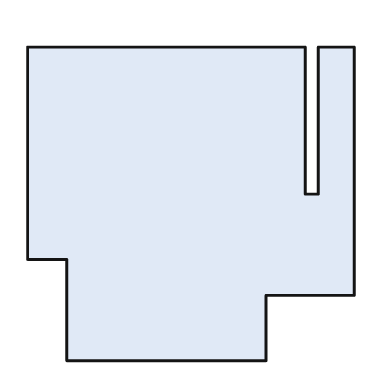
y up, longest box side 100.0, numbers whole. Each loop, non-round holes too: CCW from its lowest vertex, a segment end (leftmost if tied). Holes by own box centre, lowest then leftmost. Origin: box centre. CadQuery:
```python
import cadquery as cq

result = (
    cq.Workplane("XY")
    .moveTo(-38.0, -48.0)
    .lineTo(23.0, -48.0)
    .lineTo(23.0, -28.0)
    .lineTo(50.0, -28.0)
    .lineTo(50.0, 48.0)
    .lineTo(39.0, 48.0)
    .lineTo(39.0, 3.0)
    .lineTo(35.0, 3.0)
    .lineTo(35.0, 48.0)
    .lineTo(-50.0, 48.0)
    .lineTo(-50.0, -17.0)
    .lineTo(-38.0, -17.0)
    .close()
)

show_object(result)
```